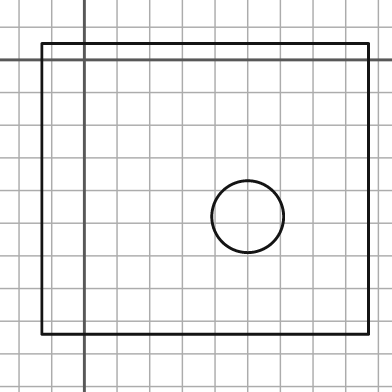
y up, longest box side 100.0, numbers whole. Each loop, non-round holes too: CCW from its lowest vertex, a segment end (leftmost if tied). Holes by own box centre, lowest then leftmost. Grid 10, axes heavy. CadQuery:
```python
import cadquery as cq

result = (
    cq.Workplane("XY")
    .moveTo(-13.0, -84.0)
    .lineTo(87.0, -84.0)
    .lineTo(87.0, 5.0)
    .lineTo(-13.0, 5.0)
    .close()
    .moveTo(50.0, -48.0)
    .circle(11.0)
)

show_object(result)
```